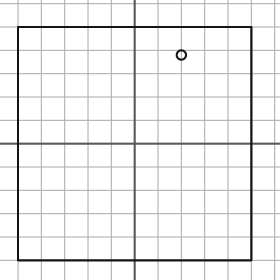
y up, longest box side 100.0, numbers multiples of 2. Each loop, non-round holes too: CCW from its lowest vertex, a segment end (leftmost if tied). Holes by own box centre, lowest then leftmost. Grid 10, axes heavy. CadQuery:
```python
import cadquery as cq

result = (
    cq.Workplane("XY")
    .moveTo(-50.0, -50.0)
    .lineTo(50.0, -50.0)
    .lineTo(50.0, 50.0)
    .lineTo(-50.0, 50.0)
    .close()
    .moveTo(20.0, 38.0)
    .circle(2.0)
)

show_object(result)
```